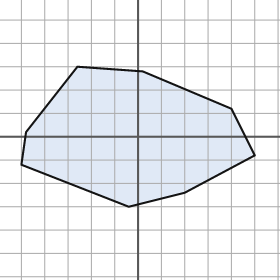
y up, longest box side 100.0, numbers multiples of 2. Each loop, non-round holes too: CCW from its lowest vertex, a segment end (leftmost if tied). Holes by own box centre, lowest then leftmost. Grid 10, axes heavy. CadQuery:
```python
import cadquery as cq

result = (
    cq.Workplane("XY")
    .moveTo(-4.0, -30.0)
    .lineTo(20.0, -24.0)
    .lineTo(50.0, -8.0)
    .lineTo(40.0, 12.0)
    .lineTo(2.0, 28.0)
    .lineTo(-26.0, 30.0)
    .lineTo(-48.0, 2.0)
    .lineTo(-50.0, -12.0)
    .close()
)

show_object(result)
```